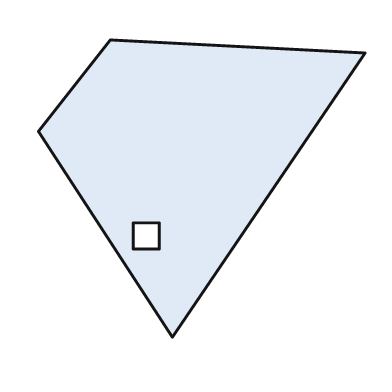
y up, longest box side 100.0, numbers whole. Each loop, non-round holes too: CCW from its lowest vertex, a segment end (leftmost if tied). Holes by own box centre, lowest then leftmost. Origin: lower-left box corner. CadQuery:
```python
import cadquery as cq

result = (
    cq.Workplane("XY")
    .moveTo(41.0, 0.0)
    .lineTo(100.0, 87.0)
    .lineTo(22.0, 91.0)
    .lineTo(0.0, 63.0)
    .close()
    .moveTo(29.0, 27.0)
    .lineTo(37.0, 27.0)
    .lineTo(37.0, 35.0)
    .lineTo(29.0, 35.0)
    .close()
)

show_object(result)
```